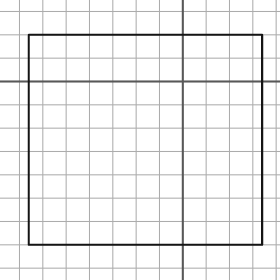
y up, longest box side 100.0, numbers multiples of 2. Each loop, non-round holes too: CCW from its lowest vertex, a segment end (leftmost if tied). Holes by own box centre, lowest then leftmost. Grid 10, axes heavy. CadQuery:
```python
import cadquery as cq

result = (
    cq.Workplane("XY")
    .moveTo(-66.0, -70.0)
    .lineTo(34.0, -70.0)
    .lineTo(34.0, 20.0)
    .lineTo(-66.0, 20.0)
    .close()
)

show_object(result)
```